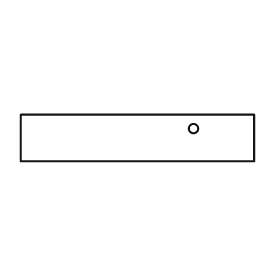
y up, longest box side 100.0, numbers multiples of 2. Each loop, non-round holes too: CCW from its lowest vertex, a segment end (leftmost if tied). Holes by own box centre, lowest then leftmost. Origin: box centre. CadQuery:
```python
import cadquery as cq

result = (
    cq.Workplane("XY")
    .moveTo(-50.0, -10.0)
    .lineTo(50.0, -10.0)
    .lineTo(50.0, 10.0)
    .lineTo(-50.0, 10.0)
    .close()
    .moveTo(24.0, 4.0)
    .circle(2.0)
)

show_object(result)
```